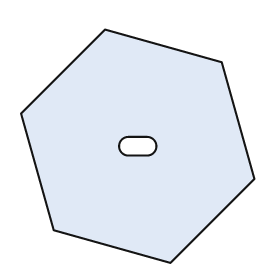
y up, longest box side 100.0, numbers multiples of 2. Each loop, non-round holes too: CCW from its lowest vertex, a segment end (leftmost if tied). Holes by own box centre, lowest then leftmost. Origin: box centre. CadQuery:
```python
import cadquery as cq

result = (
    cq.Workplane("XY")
    .moveTo(14.0, -50.0)
    .lineTo(50.0, -14.0)
    .lineTo(36.0, 36.0)
    .lineTo(-14.0, 50.0)
    .lineTo(-50.0, 14.0)
    .lineTo(-36.0, -36.0)
    .close()
    .moveTo(-4.0, -4.0)
    .lineTo(4.0, -4.0)
    .threePointArc((8.0, 0.0), (4.0, 4.0))
    .lineTo(-4.0, 4.0)
    .threePointArc((-8.0, 0.0), (-4.0, -4.0))
    .close()
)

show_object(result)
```